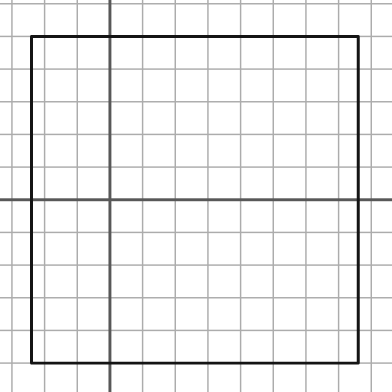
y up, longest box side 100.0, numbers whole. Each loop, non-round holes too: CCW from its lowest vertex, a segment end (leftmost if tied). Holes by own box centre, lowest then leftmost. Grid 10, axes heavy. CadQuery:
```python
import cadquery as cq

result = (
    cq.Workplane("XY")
    .moveTo(-24.0, -50.0)
    .lineTo(76.0, -50.0)
    .lineTo(76.0, 50.0)
    .lineTo(-24.0, 50.0)
    .close()
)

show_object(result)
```